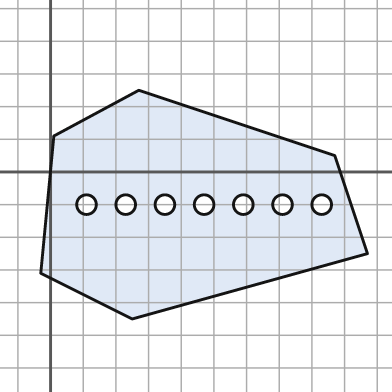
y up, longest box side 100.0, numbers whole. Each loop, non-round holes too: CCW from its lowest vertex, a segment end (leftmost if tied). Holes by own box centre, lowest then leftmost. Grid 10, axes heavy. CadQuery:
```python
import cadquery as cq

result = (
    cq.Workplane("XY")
    .moveTo(25.0, -45.0)
    .lineTo(97.0, -25.0)
    .lineTo(87.0, 5.0)
    .lineTo(27.0, 25.0)
    .lineTo(1.0, 11.0)
    .lineTo(-3.0, -31.0)
    .close()
    .moveTo(11.0, -10.0)
    .circle(3.0)
    .moveTo(23.0, -10.0)
    .circle(3.0)
    .moveTo(35.0, -10.0)
    .circle(3.0)
    .moveTo(47.0, -10.0)
    .circle(3.0)
    .moveTo(59.0, -10.0)
    .circle(3.0)
    .moveTo(71.0, -10.0)
    .circle(3.0)
    .moveTo(83.0, -10.0)
    .circle(3.0)
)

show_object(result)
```